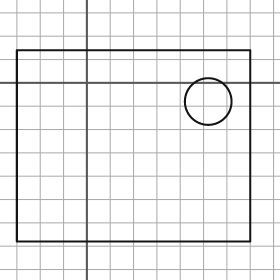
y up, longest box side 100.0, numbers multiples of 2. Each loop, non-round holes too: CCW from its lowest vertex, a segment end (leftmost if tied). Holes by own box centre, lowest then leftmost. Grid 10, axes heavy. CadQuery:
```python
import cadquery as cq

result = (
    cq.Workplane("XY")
    .moveTo(-30.0, -68.0)
    .lineTo(70.0, -68.0)
    .lineTo(70.0, 14.0)
    .lineTo(-30.0, 14.0)
    .close()
    .moveTo(52.0, -8.0)
    .circle(10.0)
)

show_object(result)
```